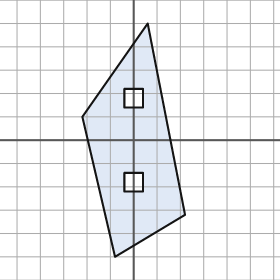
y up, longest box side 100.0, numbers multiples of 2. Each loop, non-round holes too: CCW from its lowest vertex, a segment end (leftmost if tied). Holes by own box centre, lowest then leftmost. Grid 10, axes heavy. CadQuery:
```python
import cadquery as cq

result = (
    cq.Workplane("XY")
    .moveTo(-8.0, -50.0)
    .lineTo(22.0, -32.0)
    .lineTo(6.0, 50.0)
    .lineTo(-22.0, 10.0)
    .close()
    .moveTo(-4.0, -22.0)
    .lineTo(4.0, -22.0)
    .lineTo(4.0, -14.0)
    .lineTo(-4.0, -14.0)
    .close()
    .moveTo(-4.0, 14.0)
    .lineTo(4.0, 14.0)
    .lineTo(4.0, 22.0)
    .lineTo(-4.0, 22.0)
    .close()
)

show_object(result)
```